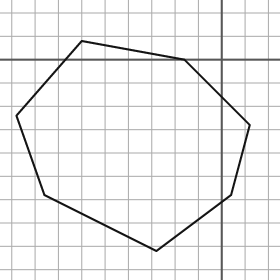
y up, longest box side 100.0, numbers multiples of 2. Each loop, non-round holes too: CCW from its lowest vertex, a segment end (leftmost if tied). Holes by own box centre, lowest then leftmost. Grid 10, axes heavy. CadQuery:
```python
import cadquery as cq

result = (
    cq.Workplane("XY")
    .moveTo(-28.0, -82.0)
    .lineTo(4.0, -58.0)
    .lineTo(12.0, -28.0)
    .lineTo(-16.0, 0.0)
    .lineTo(-60.0, 8.0)
    .lineTo(-88.0, -24.0)
    .lineTo(-76.0, -58.0)
    .close()
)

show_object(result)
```